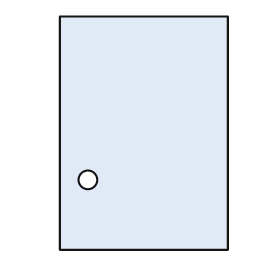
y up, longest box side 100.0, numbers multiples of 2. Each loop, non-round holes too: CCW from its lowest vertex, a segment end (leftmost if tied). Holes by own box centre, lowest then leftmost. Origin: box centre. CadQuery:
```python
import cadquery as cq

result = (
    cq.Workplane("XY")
    .moveTo(-36.0, -50.0)
    .lineTo(36.0, -50.0)
    .lineTo(36.0, 50.0)
    .lineTo(-36.0, 50.0)
    .close()
    .moveTo(-24.0, -20.0)
    .circle(4.0)
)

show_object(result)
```